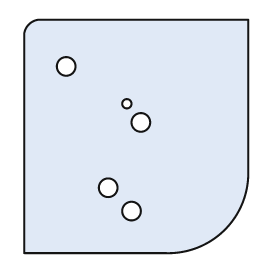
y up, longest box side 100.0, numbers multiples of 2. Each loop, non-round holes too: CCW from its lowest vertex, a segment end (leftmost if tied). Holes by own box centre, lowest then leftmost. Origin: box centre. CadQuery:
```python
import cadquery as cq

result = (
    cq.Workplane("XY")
    .moveTo(-48.0, -50.0)
    .lineTo(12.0, -50.0)
    .threePointArc((38.0, -40.0), (48.0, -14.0))
    .lineTo(48.0, 50.0)
    .lineTo(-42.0, 50.0)
    .threePointArc((-46.0, 48.0), (-48.0, 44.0))
    .close()
    .moveTo(-2.0, -32.0)
    .circle(4.0)
    .moveTo(-12.0, -22.0)
    .circle(4.0)
    .moveTo(2.0, 6.0)
    .circle(4.0)
    .moveTo(-4.0, 14.0)
    .circle(2.0)
    .moveTo(-30.0, 30.0)
    .circle(4.0)
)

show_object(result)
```